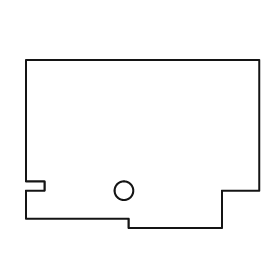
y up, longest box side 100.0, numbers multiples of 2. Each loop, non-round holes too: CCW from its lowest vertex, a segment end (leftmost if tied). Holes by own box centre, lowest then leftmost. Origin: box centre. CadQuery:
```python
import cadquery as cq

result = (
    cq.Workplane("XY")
    .moveTo(-6.0, -36.0)
    .lineTo(34.0, -36.0)
    .lineTo(34.0, -20.0)
    .lineTo(50.0, -20.0)
    .lineTo(50.0, 36.0)
    .lineTo(-50.0, 36.0)
    .lineTo(-50.0, -16.0)
    .lineTo(-42.0, -16.0)
    .lineTo(-42.0, -20.0)
    .lineTo(-50.0, -20.0)
    .lineTo(-50.0, -32.0)
    .lineTo(-6.0, -32.0)
    .close()
    .moveTo(-8.0, -20.0)
    .circle(4.0)
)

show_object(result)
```